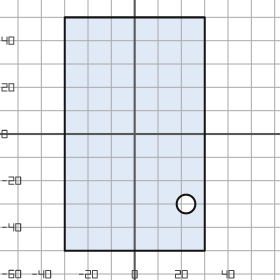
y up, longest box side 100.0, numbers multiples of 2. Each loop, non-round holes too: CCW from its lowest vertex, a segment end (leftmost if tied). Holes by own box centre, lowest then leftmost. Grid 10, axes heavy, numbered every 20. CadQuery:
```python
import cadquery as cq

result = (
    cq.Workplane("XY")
    .moveTo(-30.0, -50.0)
    .lineTo(30.0, -50.0)
    .lineTo(30.0, 50.0)
    .lineTo(-30.0, 50.0)
    .close()
    .moveTo(22.0, -30.0)
    .circle(4.0)
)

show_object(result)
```